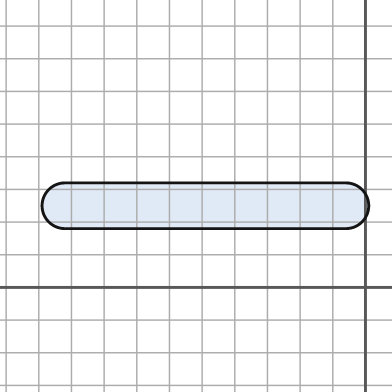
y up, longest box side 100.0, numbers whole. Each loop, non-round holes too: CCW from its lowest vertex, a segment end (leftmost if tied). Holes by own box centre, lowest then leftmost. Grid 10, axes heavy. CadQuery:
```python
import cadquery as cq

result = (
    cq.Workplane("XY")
    .moveTo(-92.0, 18.0)
    .lineTo(-6.0, 18.0)
    .threePointArc((1.0, 25.0), (-6.0, 32.0))
    .lineTo(-92.0, 32.0)
    .threePointArc((-99.0, 25.0), (-92.0, 18.0))
    .close()
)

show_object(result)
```